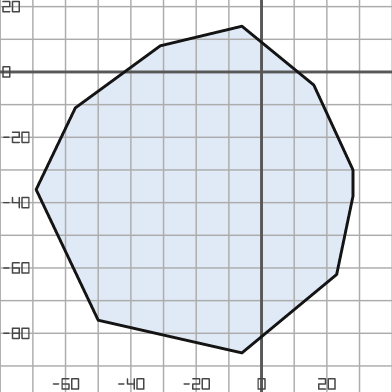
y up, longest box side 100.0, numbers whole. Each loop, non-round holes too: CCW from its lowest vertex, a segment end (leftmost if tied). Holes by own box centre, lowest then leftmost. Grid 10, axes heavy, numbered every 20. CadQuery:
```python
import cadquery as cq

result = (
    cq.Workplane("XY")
    .moveTo(-6.0, -86.0)
    .lineTo(23.0, -62.0)
    .lineTo(28.0, -38.0)
    .lineTo(28.0, -30.0)
    .lineTo(16.0, -4.0)
    .lineTo(-6.0, 14.0)
    .lineTo(-31.0, 8.0)
    .lineTo(-57.0, -11.0)
    .lineTo(-69.0, -36.0)
    .lineTo(-50.0, -76.0)
    .close()
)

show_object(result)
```